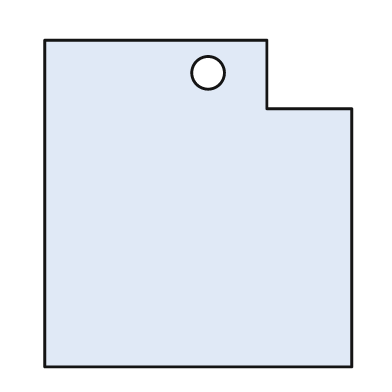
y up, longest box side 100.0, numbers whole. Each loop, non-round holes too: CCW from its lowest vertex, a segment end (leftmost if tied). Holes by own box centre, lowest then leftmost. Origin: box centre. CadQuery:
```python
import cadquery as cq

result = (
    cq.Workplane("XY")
    .moveTo(-47.0, -50.0)
    .lineTo(47.0, -50.0)
    .lineTo(47.0, 29.0)
    .lineTo(21.0, 29.0)
    .lineTo(21.0, 50.0)
    .lineTo(-47.0, 50.0)
    .close()
    .moveTo(3.0, 40.0)
    .circle(5.0)
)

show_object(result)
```